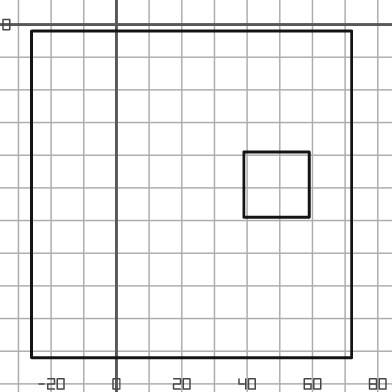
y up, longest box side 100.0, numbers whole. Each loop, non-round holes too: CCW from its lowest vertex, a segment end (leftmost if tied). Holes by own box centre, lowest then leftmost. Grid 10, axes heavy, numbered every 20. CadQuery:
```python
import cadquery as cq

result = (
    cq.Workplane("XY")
    .moveTo(-26.0, -102.0)
    .lineTo(72.0, -102.0)
    .lineTo(72.0, -2.0)
    .lineTo(-26.0, -2.0)
    .close()
    .moveTo(39.0, -59.0)
    .lineTo(59.0, -59.0)
    .lineTo(59.0, -39.0)
    .lineTo(39.0, -39.0)
    .close()
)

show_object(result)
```